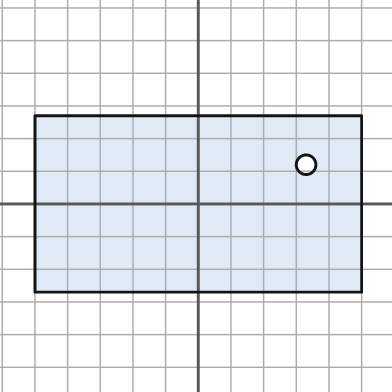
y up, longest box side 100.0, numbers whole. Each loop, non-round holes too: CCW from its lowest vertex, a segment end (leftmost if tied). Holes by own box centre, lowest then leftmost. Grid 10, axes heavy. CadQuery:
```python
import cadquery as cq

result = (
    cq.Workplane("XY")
    .moveTo(-50.0, -27.0)
    .lineTo(50.0, -27.0)
    .lineTo(50.0, 27.0)
    .lineTo(-50.0, 27.0)
    .close()
    .moveTo(33.0, 12.0)
    .circle(3.0)
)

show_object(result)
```